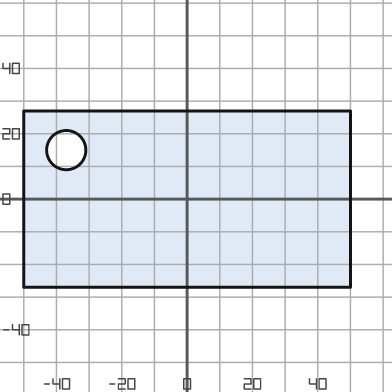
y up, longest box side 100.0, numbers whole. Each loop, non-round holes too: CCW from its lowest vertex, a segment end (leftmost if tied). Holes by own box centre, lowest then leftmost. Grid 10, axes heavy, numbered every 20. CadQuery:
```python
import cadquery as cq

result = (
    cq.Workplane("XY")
    .moveTo(-50.0, -27.0)
    .lineTo(50.0, -27.0)
    .lineTo(50.0, 27.0)
    .lineTo(-50.0, 27.0)
    .close()
    .moveTo(-37.0, 15.0)
    .circle(6.0)
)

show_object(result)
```